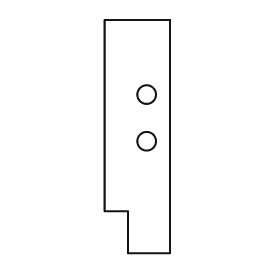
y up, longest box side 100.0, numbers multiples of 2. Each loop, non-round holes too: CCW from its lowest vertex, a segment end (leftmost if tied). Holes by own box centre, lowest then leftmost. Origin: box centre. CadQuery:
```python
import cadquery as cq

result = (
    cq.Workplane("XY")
    .moveTo(-4.0, -50.0)
    .lineTo(14.0, -50.0)
    .lineTo(14.0, 50.0)
    .lineTo(-14.0, 50.0)
    .lineTo(-14.0, -32.0)
    .lineTo(-4.0, -32.0)
    .close()
    .moveTo(4.0, -2.0)
    .circle(4.0)
    .moveTo(4.0, 18.0)
    .circle(4.0)
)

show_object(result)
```